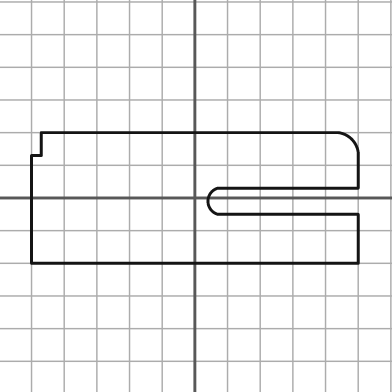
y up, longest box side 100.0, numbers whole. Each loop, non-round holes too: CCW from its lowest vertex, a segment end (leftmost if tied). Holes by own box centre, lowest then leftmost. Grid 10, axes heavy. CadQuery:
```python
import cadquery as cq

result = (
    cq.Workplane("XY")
    .moveTo(-50.0, -20.0)
    .lineTo(50.0, -20.0)
    .lineTo(50.0, -5.0)
    .lineTo(7.0, -5.0)
    .threePointArc((4.0, -1.0), (7.0, 3.0))
    .lineTo(50.0, 3.0)
    .lineTo(50.0, 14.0)
    .threePointArc((48.0, 18.0), (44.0, 20.0))
    .lineTo(-47.0, 20.0)
    .lineTo(-47.0, 13.0)
    .lineTo(-50.0, 13.0)
    .close()
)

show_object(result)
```